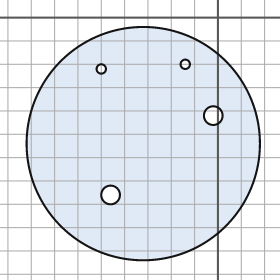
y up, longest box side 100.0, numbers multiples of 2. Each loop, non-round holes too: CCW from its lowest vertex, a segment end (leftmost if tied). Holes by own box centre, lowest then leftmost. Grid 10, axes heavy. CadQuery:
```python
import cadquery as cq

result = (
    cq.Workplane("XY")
    .moveTo(-32.0, -54.0)
    .circle(50.0)
    .moveTo(-46.0, -76.0)
    .circle(4.0)
    .moveTo(-2.0, -42.0)
    .circle(4.0)
    .moveTo(-50.0, -22.0)
    .circle(2.0)
    .moveTo(-14.0, -20.0)
    .circle(2.0)
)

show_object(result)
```